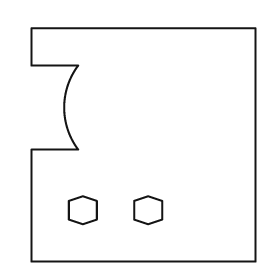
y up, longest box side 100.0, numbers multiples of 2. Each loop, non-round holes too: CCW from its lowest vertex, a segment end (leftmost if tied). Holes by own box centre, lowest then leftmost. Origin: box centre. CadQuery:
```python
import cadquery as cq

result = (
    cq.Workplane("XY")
    .moveTo(-48.0, -50.0)
    .lineTo(48.0, -50.0)
    .lineTo(48.0, 50.0)
    .lineTo(-48.0, 50.0)
    .lineTo(-48.0, 34.0)
    .lineTo(-28.0, 34.0)
    .threePointArc((-34.0, 16.0), (-28.0, -2.0))
    .lineTo(-48.0, -2.0)
    .close()
    .moveTo(-26.0, -34.0)
    .lineTo(-20.0, -32.0)
    .lineTo(-20.0, -24.0)
    .lineTo(-26.0, -22.0)
    .lineTo(-32.0, -24.0)
    .lineTo(-32.0, -32.0)
    .close()
    .moveTo(2.0, -34.0)
    .lineTo(8.0, -32.0)
    .lineTo(8.0, -24.0)
    .lineTo(2.0, -22.0)
    .lineTo(-4.0, -24.0)
    .lineTo(-4.0, -32.0)
    .close()
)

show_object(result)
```